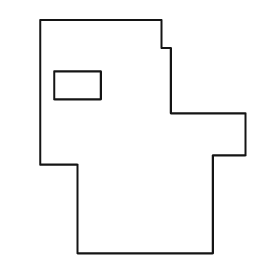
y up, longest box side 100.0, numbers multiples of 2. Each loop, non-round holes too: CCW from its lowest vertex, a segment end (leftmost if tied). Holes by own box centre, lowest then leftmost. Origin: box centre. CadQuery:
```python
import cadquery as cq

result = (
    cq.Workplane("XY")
    .moveTo(-28.0, -50.0)
    .lineTo(30.0, -50.0)
    .lineTo(30.0, -8.0)
    .lineTo(44.0, -8.0)
    .lineTo(44.0, 10.0)
    .lineTo(12.0, 10.0)
    .lineTo(12.0, 38.0)
    .lineTo(8.0, 38.0)
    .lineTo(8.0, 50.0)
    .lineTo(-44.0, 50.0)
    .lineTo(-44.0, -12.0)
    .lineTo(-28.0, -12.0)
    .close()
    .moveTo(-38.0, 16.0)
    .lineTo(-18.0, 16.0)
    .lineTo(-18.0, 28.0)
    .lineTo(-38.0, 28.0)
    .close()
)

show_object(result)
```